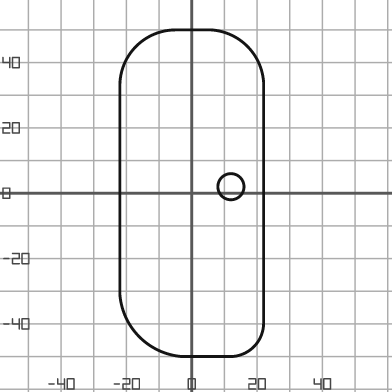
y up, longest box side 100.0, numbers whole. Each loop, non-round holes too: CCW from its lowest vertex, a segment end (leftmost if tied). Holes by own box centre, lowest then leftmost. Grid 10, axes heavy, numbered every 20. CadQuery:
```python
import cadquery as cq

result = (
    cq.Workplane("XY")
    .moveTo(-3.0, -50.0)
    .lineTo(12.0, -50.0)
    .threePointArc((19.0, -47.0), (22.0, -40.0))
    .lineTo(22.0, 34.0)
    .threePointArc((17.0, 45.0), (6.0, 50.0))
    .lineTo(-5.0, 50.0)
    .threePointArc((-17.0, 45.0), (-22.0, 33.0))
    .lineTo(-22.0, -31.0)
    .threePointArc((-16.0, -44.0), (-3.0, -50.0))
    .close()
    .moveTo(12.0, 2.0)
    .circle(4.0)
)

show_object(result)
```